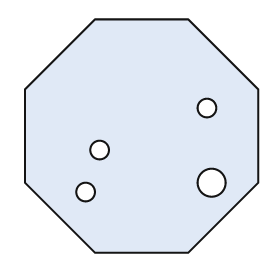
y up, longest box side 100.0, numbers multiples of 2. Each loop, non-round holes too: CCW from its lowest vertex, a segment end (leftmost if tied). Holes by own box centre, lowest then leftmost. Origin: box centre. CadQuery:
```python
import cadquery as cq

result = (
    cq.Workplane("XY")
    .moveTo(-20.0, -50.0)
    .lineTo(20.0, -50.0)
    .lineTo(50.0, -20.0)
    .lineTo(50.0, 20.0)
    .lineTo(20.0, 50.0)
    .lineTo(-20.0, 50.0)
    .lineTo(-50.0, 20.0)
    .lineTo(-50.0, -20.0)
    .close()
    .moveTo(-24.0, -24.0)
    .circle(4.0)
    .moveTo(30.0, -20.0)
    .circle(6.0)
    .moveTo(-18.0, -6.0)
    .circle(4.0)
    .moveTo(28.0, 12.0)
    .circle(4.0)
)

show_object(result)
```